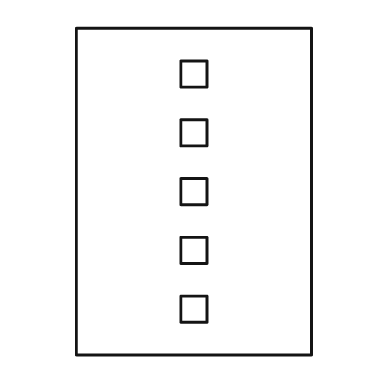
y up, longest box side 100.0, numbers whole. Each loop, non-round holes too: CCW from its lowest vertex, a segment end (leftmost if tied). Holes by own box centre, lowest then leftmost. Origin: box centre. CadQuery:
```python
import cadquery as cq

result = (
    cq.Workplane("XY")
    .moveTo(-36.0, -50.0)
    .lineTo(36.0, -50.0)
    .lineTo(36.0, 50.0)
    .lineTo(-36.0, 50.0)
    .close()
    .moveTo(-4.0, -40.0)
    .lineTo(4.0, -40.0)
    .lineTo(4.0, -32.0)
    .lineTo(-4.0, -32.0)
    .close()
    .moveTo(-4.0, -22.0)
    .lineTo(4.0, -22.0)
    .lineTo(4.0, -14.0)
    .lineTo(-4.0, -14.0)
    .close()
    .moveTo(-4.0, -4.0)
    .lineTo(4.0, -4.0)
    .lineTo(4.0, 4.0)
    .lineTo(-4.0, 4.0)
    .close()
    .moveTo(-4.0, 14.0)
    .lineTo(4.0, 14.0)
    .lineTo(4.0, 22.0)
    .lineTo(-4.0, 22.0)
    .close()
    .moveTo(-4.0, 32.0)
    .lineTo(4.0, 32.0)
    .lineTo(4.0, 40.0)
    .lineTo(-4.0, 40.0)
    .close()
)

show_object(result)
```